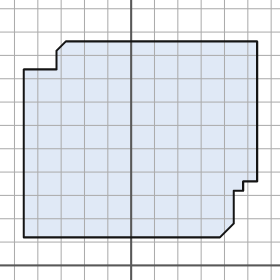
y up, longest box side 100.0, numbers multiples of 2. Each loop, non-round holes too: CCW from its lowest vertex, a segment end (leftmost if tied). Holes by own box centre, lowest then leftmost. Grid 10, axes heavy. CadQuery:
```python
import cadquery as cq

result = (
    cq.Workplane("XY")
    .moveTo(-46.0, 12.0)
    .lineTo(38.0, 12.0)
    .lineTo(44.0, 18.0)
    .lineTo(44.0, 32.0)
    .lineTo(48.0, 32.0)
    .lineTo(48.0, 36.0)
    .lineTo(54.0, 36.0)
    .lineTo(54.0, 96.0)
    .lineTo(-28.0, 96.0)
    .lineTo(-32.0, 92.0)
    .lineTo(-32.0, 84.0)
    .lineTo(-46.0, 84.0)
    .close()
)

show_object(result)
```